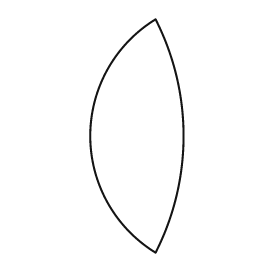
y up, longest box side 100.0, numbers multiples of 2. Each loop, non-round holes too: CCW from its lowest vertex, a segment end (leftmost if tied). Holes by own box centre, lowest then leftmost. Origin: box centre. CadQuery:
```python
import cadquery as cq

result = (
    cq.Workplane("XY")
    .moveTo(8.0, -50.0)
    .threePointArc((20.0, 0.0), (8.0, 50.0))
    .threePointArc((-20.0, 0.0), (8.0, -50.0))
    .close()
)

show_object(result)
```